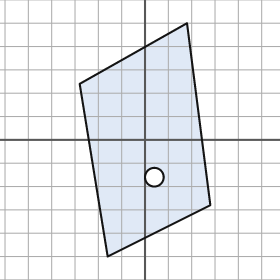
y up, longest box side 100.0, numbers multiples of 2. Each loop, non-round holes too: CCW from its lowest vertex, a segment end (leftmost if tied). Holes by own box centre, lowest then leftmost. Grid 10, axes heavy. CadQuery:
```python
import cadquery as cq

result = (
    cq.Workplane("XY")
    .moveTo(-16.0, -50.0)
    .lineTo(28.0, -28.0)
    .lineTo(18.0, 50.0)
    .lineTo(-28.0, 24.0)
    .close()
    .moveTo(4.0, -16.0)
    .circle(4.0)
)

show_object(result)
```